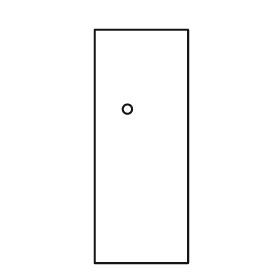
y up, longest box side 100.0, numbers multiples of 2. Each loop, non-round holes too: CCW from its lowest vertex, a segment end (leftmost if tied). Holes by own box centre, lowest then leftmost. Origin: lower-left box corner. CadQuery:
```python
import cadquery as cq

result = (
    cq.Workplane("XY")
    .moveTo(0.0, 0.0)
    .lineTo(40.0, 0.0)
    .lineTo(40.0, 100.0)
    .lineTo(0.0, 100.0)
    .close()
    .moveTo(14.0, 66.0)
    .circle(2.0)
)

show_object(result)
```